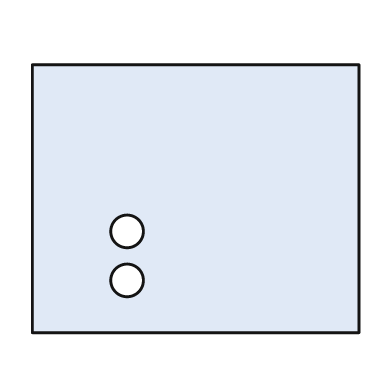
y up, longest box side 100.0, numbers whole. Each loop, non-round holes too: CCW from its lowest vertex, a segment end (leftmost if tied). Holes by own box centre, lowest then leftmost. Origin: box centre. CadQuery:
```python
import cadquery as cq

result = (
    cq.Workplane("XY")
    .moveTo(-50.0, -41.0)
    .lineTo(50.0, -41.0)
    .lineTo(50.0, 41.0)
    .lineTo(-50.0, 41.0)
    .close()
    .moveTo(-21.0, -25.0)
    .circle(5.0)
    .moveTo(-21.0, -10.0)
    .circle(5.0)
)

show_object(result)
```